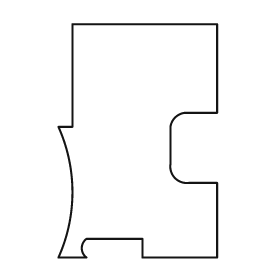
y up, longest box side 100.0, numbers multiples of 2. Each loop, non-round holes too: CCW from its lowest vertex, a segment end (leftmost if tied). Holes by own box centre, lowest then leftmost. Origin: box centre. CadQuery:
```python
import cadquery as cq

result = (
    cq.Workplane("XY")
    .moveTo(-34.0, -50.0)
    .lineTo(-22.0, -50.0)
    .threePointArc((-24.0, -46.0), (-22.0, -42.0))
    .lineTo(2.0, -42.0)
    .lineTo(2.0, -50.0)
    .lineTo(34.0, -50.0)
    .lineTo(34.0, -18.0)
    .lineTo(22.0, -18.0)
    .threePointArc((16.0, -16.0), (14.0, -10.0))
    .lineTo(14.0, 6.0)
    .threePointArc((16.0, 10.0), (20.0, 12.0))
    .lineTo(34.0, 12.0)
    .lineTo(34.0, 50.0)
    .lineTo(-28.0, 50.0)
    .lineTo(-28.0, 6.0)
    .lineTo(-34.0, 6.0)
    .threePointArc((-28.0, -22.0), (-34.0, -50.0))
    .close()
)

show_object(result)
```